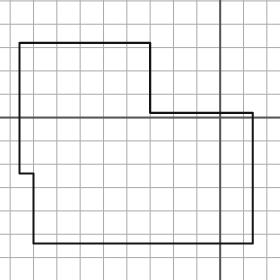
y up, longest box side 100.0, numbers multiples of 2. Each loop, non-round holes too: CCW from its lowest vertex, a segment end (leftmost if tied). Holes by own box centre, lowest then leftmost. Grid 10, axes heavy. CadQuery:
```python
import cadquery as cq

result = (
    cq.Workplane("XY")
    .moveTo(-80.0, -54.0)
    .lineTo(14.0, -54.0)
    .lineTo(14.0, 2.0)
    .lineTo(-30.0, 2.0)
    .lineTo(-30.0, 32.0)
    .lineTo(-86.0, 32.0)
    .lineTo(-86.0, -24.0)
    .lineTo(-80.0, -24.0)
    .close()
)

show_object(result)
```